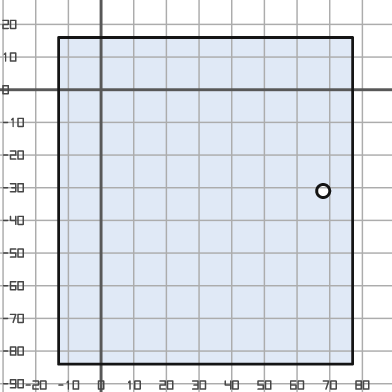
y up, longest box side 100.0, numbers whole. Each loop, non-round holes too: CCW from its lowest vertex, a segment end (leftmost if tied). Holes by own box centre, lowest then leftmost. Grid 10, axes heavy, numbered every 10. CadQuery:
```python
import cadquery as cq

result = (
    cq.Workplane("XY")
    .moveTo(-13.0, -84.0)
    .lineTo(77.0, -84.0)
    .lineTo(77.0, 16.0)
    .lineTo(-13.0, 16.0)
    .close()
    .moveTo(68.0, -31.0)
    .circle(2.0)
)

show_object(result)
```